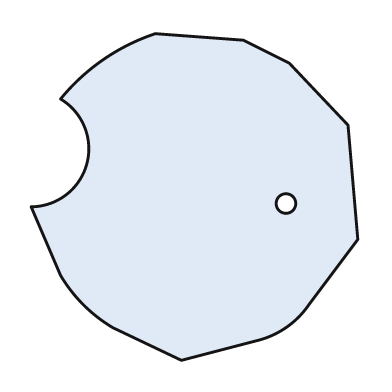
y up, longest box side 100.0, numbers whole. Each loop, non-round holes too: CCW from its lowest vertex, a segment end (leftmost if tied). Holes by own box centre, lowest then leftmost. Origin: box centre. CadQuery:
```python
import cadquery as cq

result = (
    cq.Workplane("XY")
    .moveTo(-4.0, -50.0)
    .lineTo(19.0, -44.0)
    .threePointArc((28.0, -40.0), (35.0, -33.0))
    .lineTo(50.0, -13.0)
    .lineTo(47.0, 22.0)
    .lineTo(29.0, 41.0)
    .lineTo(15.0, 48.0)
    .lineTo(-12.0, 50.0)
    .threePointArc((-28.0, 42.0), (-41.0, 30.0))
    .threePointArc((-33.0, 10.0), (-50.0, -3.0))
    .lineTo(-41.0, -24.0)
    .threePointArc((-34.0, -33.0), (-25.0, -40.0))
    .close()
    .moveTo(28.0, -2.0)
    .circle(3.0)
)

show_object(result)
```